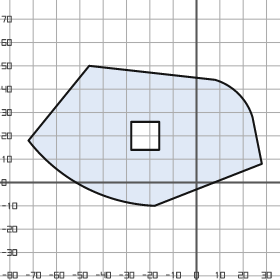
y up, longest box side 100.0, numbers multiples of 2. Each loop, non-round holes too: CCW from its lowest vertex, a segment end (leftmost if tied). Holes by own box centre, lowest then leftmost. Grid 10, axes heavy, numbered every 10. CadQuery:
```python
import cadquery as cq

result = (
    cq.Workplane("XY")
    .moveTo(-18.0, -10.0)
    .lineTo(28.0, 8.0)
    .lineTo(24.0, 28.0)
    .threePointArc((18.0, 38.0), (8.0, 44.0))
    .lineTo(-46.0, 50.0)
    .lineTo(-72.0, 18.0)
    .threePointArc((-48.0, -2.0), (-18.0, -10.0))
    .close()
    .moveTo(-28.0, 14.0)
    .lineTo(-16.0, 14.0)
    .lineTo(-16.0, 26.0)
    .lineTo(-28.0, 26.0)
    .close()
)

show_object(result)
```